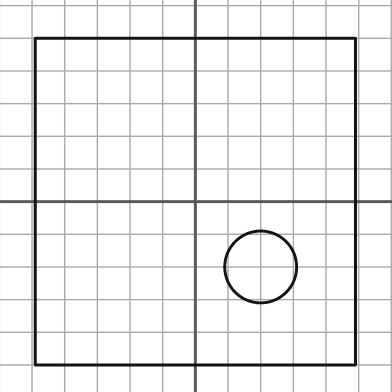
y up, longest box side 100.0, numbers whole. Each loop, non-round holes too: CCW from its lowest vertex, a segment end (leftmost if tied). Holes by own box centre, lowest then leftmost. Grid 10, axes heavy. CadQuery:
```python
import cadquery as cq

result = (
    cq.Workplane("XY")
    .moveTo(-49.0, -50.0)
    .lineTo(49.0, -50.0)
    .lineTo(49.0, 50.0)
    .lineTo(-49.0, 50.0)
    .close()
    .moveTo(20.0, -20.0)
    .circle(11.0)
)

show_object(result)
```